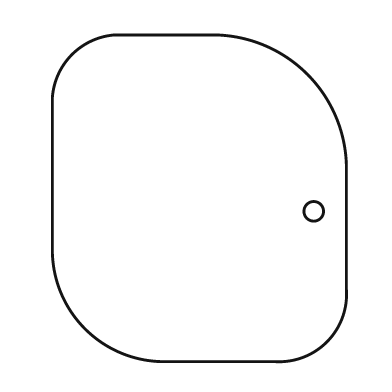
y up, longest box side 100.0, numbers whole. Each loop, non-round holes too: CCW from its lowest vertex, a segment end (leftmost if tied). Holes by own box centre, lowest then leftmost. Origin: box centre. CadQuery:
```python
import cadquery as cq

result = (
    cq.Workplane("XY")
    .moveTo(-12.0, -50.0)
    .lineTo(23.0, -50.0)
    .threePointArc((39.0, -44.0), (45.0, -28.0))
    .lineTo(45.0, 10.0)
    .threePointArc((33.0, 38.0), (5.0, 50.0))
    .lineTo(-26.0, 50.0)
    .threePointArc((-39.0, 44.0), (-45.0, 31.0))
    .lineTo(-45.0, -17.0)
    .threePointArc((-35.0, -40.0), (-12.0, -50.0))
    .close()
    .moveTo(35.0, -4.0)
    .circle(3.0)
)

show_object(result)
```